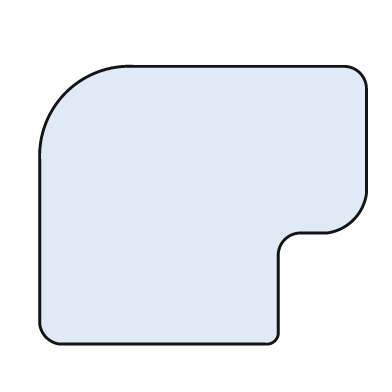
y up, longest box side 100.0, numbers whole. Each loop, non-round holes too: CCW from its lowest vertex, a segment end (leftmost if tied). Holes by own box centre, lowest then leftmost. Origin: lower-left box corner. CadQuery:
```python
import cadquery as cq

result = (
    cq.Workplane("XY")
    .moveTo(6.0, 0.0)
    .lineTo(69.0, 0.0)
    .threePointArc((72.0, 1.0), (73.0, 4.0))
    .lineTo(73.0, 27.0)
    .threePointArc((75.0, 32.0), (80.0, 34.0))
    .lineTo(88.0, 34.0)
    .threePointArc((96.0, 38.0), (100.0, 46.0))
    .lineTo(100.0, 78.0)
    .threePointArc((98.0, 83.0), (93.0, 85.0))
    .lineTo(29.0, 85.0)
    .threePointArc((8.0, 77.0), (0.0, 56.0))
    .lineTo(0.0, 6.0)
    .threePointArc((2.0, 2.0), (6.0, 0.0))
    .close()
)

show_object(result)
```